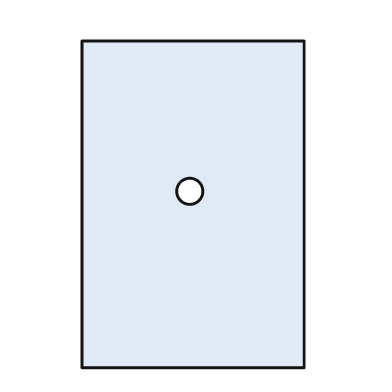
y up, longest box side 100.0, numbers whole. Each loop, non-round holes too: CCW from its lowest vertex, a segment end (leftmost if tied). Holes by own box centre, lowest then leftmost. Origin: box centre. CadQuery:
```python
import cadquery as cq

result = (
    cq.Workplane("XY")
    .moveTo(-34.0, -50.0)
    .lineTo(34.0, -50.0)
    .lineTo(34.0, 50.0)
    .lineTo(-34.0, 50.0)
    .close()
    .moveTo(-1.0, 4.0)
    .circle(4.0)
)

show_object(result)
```